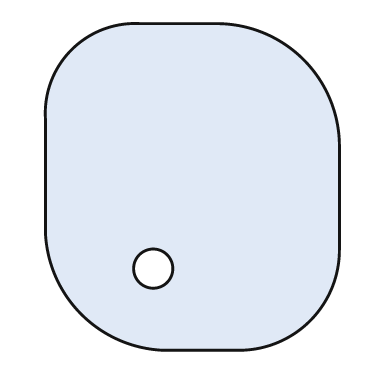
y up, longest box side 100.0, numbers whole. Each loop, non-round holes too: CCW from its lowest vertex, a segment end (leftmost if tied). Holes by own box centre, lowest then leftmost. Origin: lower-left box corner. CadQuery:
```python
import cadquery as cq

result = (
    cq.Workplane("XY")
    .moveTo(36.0, 0.0)
    .lineTo(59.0, 0.0)
    .threePointArc((81.0, 9.0), (90.0, 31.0))
    .lineTo(90.0, 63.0)
    .threePointArc((79.0, 89.0), (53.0, 100.0))
    .lineTo(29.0, 100.0)
    .threePointArc((8.0, 92.0), (0.0, 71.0))
    .lineTo(0.0, 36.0)
    .threePointArc((11.0, 11.0), (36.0, 0.0))
    .close()
    .moveTo(33.0, 25.0)
    .circle(6.0)
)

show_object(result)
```